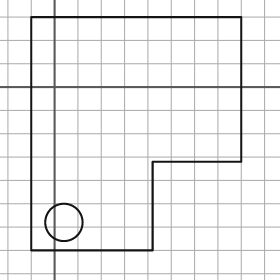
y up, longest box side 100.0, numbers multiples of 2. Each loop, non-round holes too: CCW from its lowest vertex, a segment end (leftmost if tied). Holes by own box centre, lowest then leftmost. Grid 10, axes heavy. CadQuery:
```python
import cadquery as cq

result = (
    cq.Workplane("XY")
    .moveTo(-10.0, -70.0)
    .lineTo(42.0, -70.0)
    .lineTo(42.0, -32.0)
    .lineTo(80.0, -32.0)
    .lineTo(80.0, 30.0)
    .lineTo(-10.0, 30.0)
    .close()
    .moveTo(4.0, -58.0)
    .circle(8.0)
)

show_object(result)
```